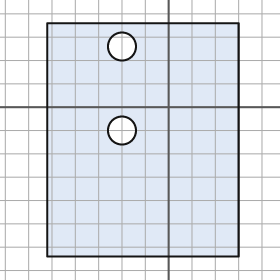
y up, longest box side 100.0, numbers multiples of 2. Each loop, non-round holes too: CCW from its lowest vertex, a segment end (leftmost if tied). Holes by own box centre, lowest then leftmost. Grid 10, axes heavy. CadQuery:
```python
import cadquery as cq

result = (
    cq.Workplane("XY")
    .moveTo(-52.0, -64.0)
    .lineTo(30.0, -64.0)
    .lineTo(30.0, 36.0)
    .lineTo(-52.0, 36.0)
    .close()
    .moveTo(-20.0, -10.0)
    .circle(6.0)
    .moveTo(-20.0, 26.0)
    .circle(6.0)
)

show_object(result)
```